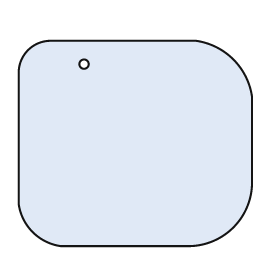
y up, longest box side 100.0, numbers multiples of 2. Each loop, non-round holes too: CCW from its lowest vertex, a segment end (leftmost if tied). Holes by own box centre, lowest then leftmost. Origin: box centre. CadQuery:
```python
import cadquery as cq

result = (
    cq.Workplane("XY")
    .moveTo(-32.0, -44.0)
    .lineTo(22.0, -44.0)
    .threePointArc((42.0, -36.0), (50.0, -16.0))
    .lineTo(50.0, 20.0)
    .threePointArc((42.0, 36.0), (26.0, 44.0))
    .lineTo(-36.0, 44.0)
    .threePointArc((-46.0, 40.0), (-50.0, 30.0))
    .lineTo(-50.0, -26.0)
    .threePointArc((-44.0, -38.0), (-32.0, -44.0))
    .close()
    .moveTo(-22.0, 34.0)
    .circle(2.0)
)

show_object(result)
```